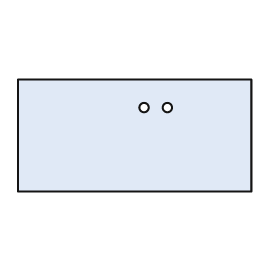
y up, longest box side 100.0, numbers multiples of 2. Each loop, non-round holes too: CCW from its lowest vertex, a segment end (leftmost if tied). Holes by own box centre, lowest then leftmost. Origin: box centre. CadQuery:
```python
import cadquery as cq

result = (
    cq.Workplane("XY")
    .moveTo(-50.0, -24.0)
    .lineTo(50.0, -24.0)
    .lineTo(50.0, 24.0)
    .lineTo(-50.0, 24.0)
    .close()
    .moveTo(4.0, 12.0)
    .circle(2.0)
    .moveTo(14.0, 12.0)
    .circle(2.0)
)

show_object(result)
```